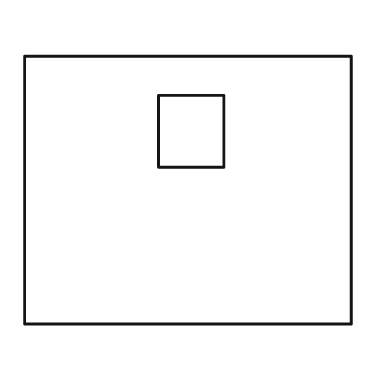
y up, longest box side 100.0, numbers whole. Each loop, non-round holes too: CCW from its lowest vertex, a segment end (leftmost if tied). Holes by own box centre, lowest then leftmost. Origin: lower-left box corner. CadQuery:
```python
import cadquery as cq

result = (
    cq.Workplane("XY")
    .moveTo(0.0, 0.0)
    .lineTo(100.0, 0.0)
    .lineTo(100.0, 82.0)
    .lineTo(0.0, 82.0)
    .close()
    .moveTo(41.0, 48.0)
    .lineTo(61.0, 48.0)
    .lineTo(61.0, 70.0)
    .lineTo(41.0, 70.0)
    .close()
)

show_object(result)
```